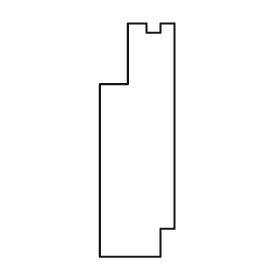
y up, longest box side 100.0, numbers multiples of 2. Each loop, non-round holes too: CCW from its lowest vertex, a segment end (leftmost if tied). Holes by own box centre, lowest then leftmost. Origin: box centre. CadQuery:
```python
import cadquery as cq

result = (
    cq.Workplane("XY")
    .moveTo(-16.0, -50.0)
    .lineTo(10.0, -50.0)
    .lineTo(10.0, -38.0)
    .lineTo(16.0, -38.0)
    .lineTo(16.0, 50.0)
    .lineTo(10.0, 50.0)
    .lineTo(10.0, 46.0)
    .lineTo(4.0, 46.0)
    .lineTo(4.0, 50.0)
    .lineTo(-4.0, 50.0)
    .lineTo(-4.0, 24.0)
    .lineTo(-16.0, 24.0)
    .close()
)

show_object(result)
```